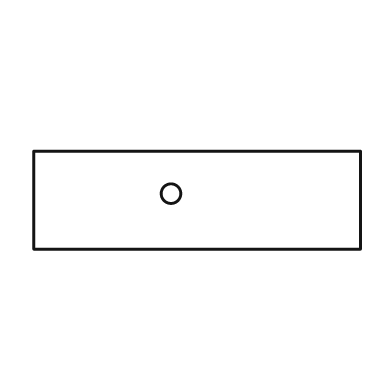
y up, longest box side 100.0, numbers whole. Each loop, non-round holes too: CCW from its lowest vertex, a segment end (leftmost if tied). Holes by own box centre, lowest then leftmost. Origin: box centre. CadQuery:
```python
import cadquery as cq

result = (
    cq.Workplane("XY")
    .moveTo(-50.0, -15.0)
    .lineTo(50.0, -15.0)
    .lineTo(50.0, 15.0)
    .lineTo(-50.0, 15.0)
    .close()
    .moveTo(-8.0, 2.0)
    .circle(3.0)
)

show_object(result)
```